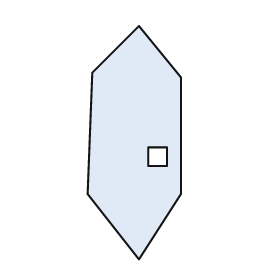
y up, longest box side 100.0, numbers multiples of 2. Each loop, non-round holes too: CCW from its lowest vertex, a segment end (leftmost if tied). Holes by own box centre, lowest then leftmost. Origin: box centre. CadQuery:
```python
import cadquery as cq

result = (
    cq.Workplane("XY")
    .moveTo(2.0, -50.0)
    .lineTo(20.0, -22.0)
    .lineTo(20.0, 28.0)
    .lineTo(2.0, 50.0)
    .lineTo(-18.0, 30.0)
    .lineTo(-20.0, -22.0)
    .close()
    .moveTo(6.0, -10.0)
    .lineTo(14.0, -10.0)
    .lineTo(14.0, -2.0)
    .lineTo(6.0, -2.0)
    .close()
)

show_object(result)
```